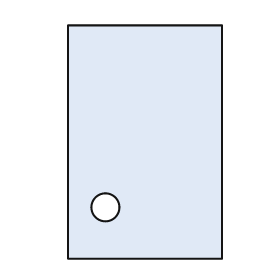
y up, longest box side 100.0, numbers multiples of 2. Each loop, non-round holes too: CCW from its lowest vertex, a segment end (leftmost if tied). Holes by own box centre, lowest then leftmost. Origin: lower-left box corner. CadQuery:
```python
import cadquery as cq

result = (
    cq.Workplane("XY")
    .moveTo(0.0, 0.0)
    .lineTo(66.0, 0.0)
    .lineTo(66.0, 100.0)
    .lineTo(0.0, 100.0)
    .close()
    .moveTo(16.0, 22.0)
    .circle(6.0)
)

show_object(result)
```